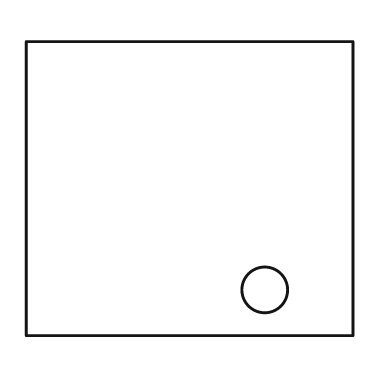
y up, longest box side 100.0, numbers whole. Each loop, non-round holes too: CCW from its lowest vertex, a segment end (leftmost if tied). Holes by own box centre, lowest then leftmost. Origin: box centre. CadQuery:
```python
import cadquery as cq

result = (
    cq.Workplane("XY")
    .moveTo(-50.0, -45.0)
    .lineTo(50.0, -45.0)
    .lineTo(50.0, 45.0)
    .lineTo(-50.0, 45.0)
    .close()
    .moveTo(23.0, -31.0)
    .circle(7.0)
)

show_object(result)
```